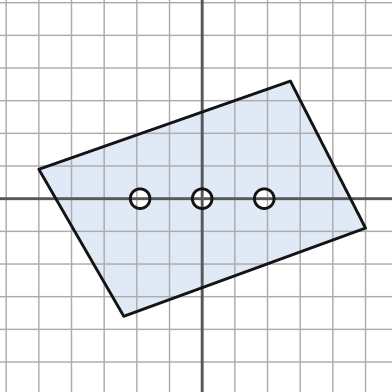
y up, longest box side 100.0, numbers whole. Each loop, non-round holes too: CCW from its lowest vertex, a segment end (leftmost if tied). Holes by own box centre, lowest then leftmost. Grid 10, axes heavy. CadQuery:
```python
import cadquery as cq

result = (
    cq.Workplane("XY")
    .moveTo(-24.0, -36.0)
    .lineTo(50.0, -9.0)
    .lineTo(27.0, 36.0)
    .lineTo(-50.0, 9.0)
    .close()
    .moveTo(-19.0, 0.0)
    .circle(3.0)
    .moveTo(0.0, 0.0)
    .circle(3.0)
    .moveTo(19.0, 0.0)
    .circle(3.0)
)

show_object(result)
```